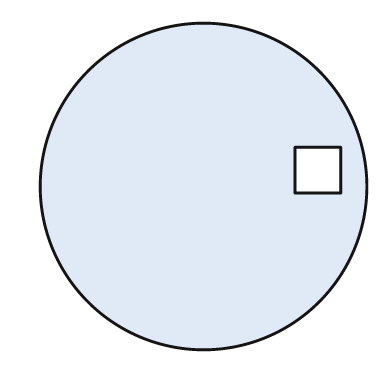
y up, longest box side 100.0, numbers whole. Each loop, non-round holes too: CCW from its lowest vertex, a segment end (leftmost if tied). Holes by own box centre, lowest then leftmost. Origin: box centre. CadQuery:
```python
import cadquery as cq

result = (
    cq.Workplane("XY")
    .moveTo(0.0, 0.0)
    .circle(50.0)
    .moveTo(28.0, -2.0)
    .lineTo(42.0, -2.0)
    .lineTo(42.0, 12.0)
    .lineTo(28.0, 12.0)
    .close()
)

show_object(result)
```